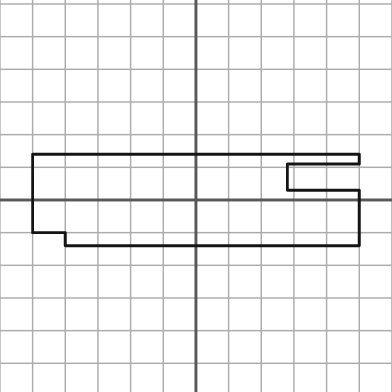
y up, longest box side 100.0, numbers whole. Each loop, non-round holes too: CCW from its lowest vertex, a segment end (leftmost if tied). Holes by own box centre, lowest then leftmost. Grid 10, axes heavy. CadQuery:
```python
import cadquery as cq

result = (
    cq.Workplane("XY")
    .moveTo(-40.0, -14.0)
    .lineTo(50.0, -14.0)
    .lineTo(50.0, 3.0)
    .lineTo(28.0, 3.0)
    .lineTo(28.0, 11.0)
    .lineTo(50.0, 11.0)
    .lineTo(50.0, 14.0)
    .lineTo(-50.0, 14.0)
    .lineTo(-50.0, -10.0)
    .lineTo(-40.0, -10.0)
    .close()
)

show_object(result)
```